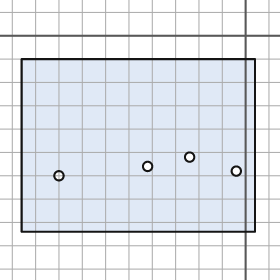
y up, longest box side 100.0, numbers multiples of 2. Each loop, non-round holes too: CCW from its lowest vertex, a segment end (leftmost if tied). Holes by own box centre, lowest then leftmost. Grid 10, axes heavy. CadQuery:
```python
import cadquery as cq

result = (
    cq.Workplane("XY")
    .moveTo(-96.0, -84.0)
    .lineTo(4.0, -84.0)
    .lineTo(4.0, -10.0)
    .lineTo(-96.0, -10.0)
    .close()
    .moveTo(-80.0, -60.0)
    .circle(2.0)
    .moveTo(-4.0, -58.0)
    .circle(2.0)
    .moveTo(-42.0, -56.0)
    .circle(2.0)
    .moveTo(-24.0, -52.0)
    .circle(2.0)
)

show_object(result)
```